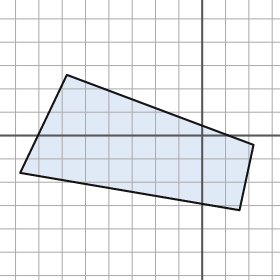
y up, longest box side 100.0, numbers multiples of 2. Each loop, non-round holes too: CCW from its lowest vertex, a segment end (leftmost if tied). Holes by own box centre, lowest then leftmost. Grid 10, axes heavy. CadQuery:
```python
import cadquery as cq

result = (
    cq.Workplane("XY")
    .moveTo(16.0, -32.0)
    .lineTo(22.0, -4.0)
    .lineTo(-58.0, 26.0)
    .lineTo(-78.0, -16.0)
    .close()
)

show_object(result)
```